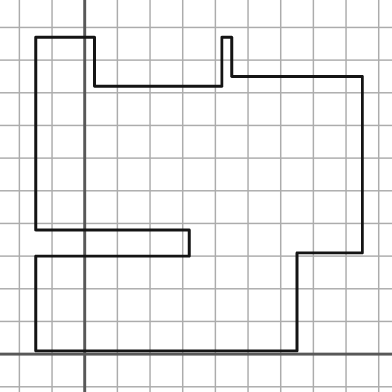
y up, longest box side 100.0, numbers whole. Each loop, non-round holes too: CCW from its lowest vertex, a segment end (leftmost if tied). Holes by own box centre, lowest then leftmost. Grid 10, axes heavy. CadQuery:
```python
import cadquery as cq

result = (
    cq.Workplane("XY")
    .moveTo(-15.0, 1.0)
    .lineTo(65.0, 1.0)
    .lineTo(65.0, 31.0)
    .lineTo(85.0, 31.0)
    .lineTo(85.0, 85.0)
    .lineTo(45.0, 85.0)
    .lineTo(45.0, 97.0)
    .lineTo(42.0, 97.0)
    .lineTo(42.0, 82.0)
    .lineTo(3.0, 82.0)
    .lineTo(3.0, 97.0)
    .lineTo(-15.0, 97.0)
    .lineTo(-15.0, 38.0)
    .lineTo(32.0, 38.0)
    .lineTo(32.0, 30.0)
    .lineTo(-15.0, 30.0)
    .close()
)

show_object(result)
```